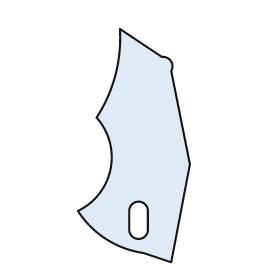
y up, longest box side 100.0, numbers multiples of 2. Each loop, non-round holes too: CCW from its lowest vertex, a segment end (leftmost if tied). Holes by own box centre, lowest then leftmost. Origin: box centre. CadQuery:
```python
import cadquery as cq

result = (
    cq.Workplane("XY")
    .moveTo(16.0, -50.0)
    .lineTo(24.0, -8.0)
    .lineTo(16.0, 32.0)
    .threePointArc((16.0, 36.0), (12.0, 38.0))
    .lineTo(-6.0, 50.0)
    .threePointArc((-8.0, 30.0), (-16.0, 12.0))
    .threePointArc((-10.0, -10.0), (-24.0, -28.0))
    .threePointArc((-12.0, -40.0), (4.0, -46.0))
    .close()
    .moveTo(-2.0, -36.0)
    .threePointArc((2.0, -40.0), (6.0, -36.0))
    .lineTo(6.0, -28.0)
    .threePointArc((2.0, -24.0), (-2.0, -28.0))
    .close()
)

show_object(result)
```